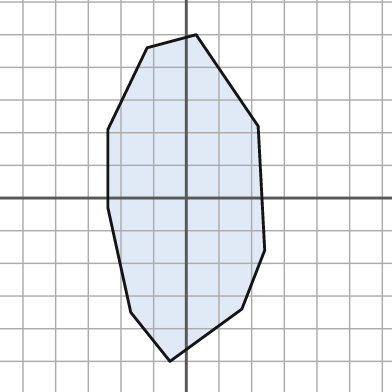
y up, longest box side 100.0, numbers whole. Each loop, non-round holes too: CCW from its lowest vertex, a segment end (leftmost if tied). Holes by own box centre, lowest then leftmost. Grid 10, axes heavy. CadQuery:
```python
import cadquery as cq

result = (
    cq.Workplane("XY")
    .moveTo(-5.0, -50.0)
    .lineTo(17.0, -34.0)
    .lineTo(24.0, -16.0)
    .lineTo(22.0, 22.0)
    .lineTo(3.0, 50.0)
    .lineTo(-12.0, 46.0)
    .lineTo(-24.0, 21.0)
    .lineTo(-24.0, -3.0)
    .lineTo(-17.0, -35.0)
    .close()
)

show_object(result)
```